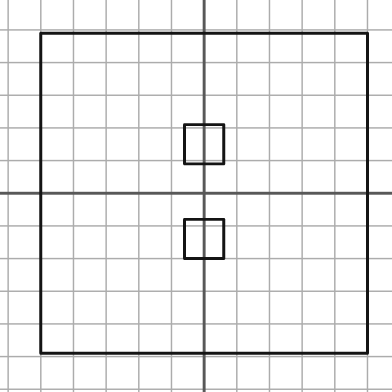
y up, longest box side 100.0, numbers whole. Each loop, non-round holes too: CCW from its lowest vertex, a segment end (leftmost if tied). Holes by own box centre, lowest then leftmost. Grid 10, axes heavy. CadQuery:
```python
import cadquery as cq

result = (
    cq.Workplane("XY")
    .moveTo(-50.0, -49.0)
    .lineTo(50.0, -49.0)
    .lineTo(50.0, 49.0)
    .lineTo(-50.0, 49.0)
    .close()
    .moveTo(-6.0, -20.0)
    .lineTo(6.0, -20.0)
    .lineTo(6.0, -8.0)
    .lineTo(-6.0, -8.0)
    .close()
    .moveTo(-6.0, 9.0)
    .lineTo(6.0, 9.0)
    .lineTo(6.0, 21.0)
    .lineTo(-6.0, 21.0)
    .close()
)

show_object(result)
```